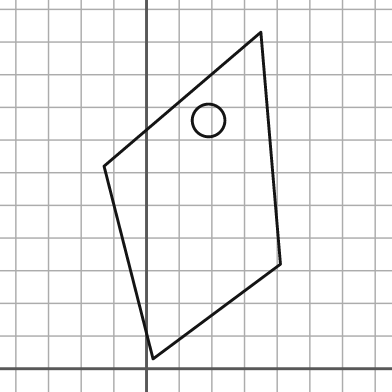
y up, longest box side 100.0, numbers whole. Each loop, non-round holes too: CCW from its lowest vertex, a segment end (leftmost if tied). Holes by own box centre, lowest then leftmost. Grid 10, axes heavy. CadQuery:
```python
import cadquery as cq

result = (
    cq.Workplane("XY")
    .moveTo(2.0, 3.0)
    .lineTo(41.0, 32.0)
    .lineTo(35.0, 103.0)
    .lineTo(-13.0, 62.0)
    .close()
    .moveTo(19.0, 76.0)
    .circle(5.0)
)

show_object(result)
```